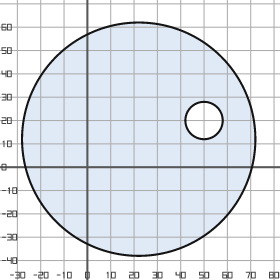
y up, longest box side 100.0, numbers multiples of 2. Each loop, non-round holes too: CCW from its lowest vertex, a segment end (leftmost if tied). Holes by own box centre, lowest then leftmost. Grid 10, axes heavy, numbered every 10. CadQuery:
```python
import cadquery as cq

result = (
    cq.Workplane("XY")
    .moveTo(22.0, 12.0)
    .circle(50.0)
    .moveTo(50.0, 20.0)
    .circle(8.0)
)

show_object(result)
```